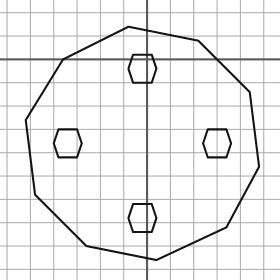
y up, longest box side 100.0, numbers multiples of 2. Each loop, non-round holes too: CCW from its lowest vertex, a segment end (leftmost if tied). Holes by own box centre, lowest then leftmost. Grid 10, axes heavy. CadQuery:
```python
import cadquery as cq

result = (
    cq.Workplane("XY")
    .moveTo(4.0, -86.0)
    .lineTo(34.0, -72.0)
    .lineTo(48.0, -46.0)
    .lineTo(44.0, -14.0)
    .lineTo(22.0, 8.0)
    .lineTo(-8.0, 14.0)
    .lineTo(-36.0, 0.0)
    .lineTo(-52.0, -26.0)
    .lineTo(-48.0, -58.0)
    .lineTo(-26.0, -80.0)
    .close()
    .moveTo(-6.0, -74.0)
    .lineTo(2.0, -74.0)
    .lineTo(4.0, -68.0)
    .lineTo(2.0, -62.0)
    .lineTo(-6.0, -62.0)
    .lineTo(-8.0, -68.0)
    .close()
    .moveTo(-38.0, -42.0)
    .lineTo(-30.0, -42.0)
    .lineTo(-28.0, -36.0)
    .lineTo(-30.0, -30.0)
    .lineTo(-38.0, -30.0)
    .lineTo(-40.0, -36.0)
    .close()
    .moveTo(26.0, -42.0)
    .lineTo(34.0, -42.0)
    .lineTo(36.0, -36.0)
    .lineTo(34.0, -30.0)
    .lineTo(26.0, -30.0)
    .lineTo(24.0, -36.0)
    .close()
    .moveTo(-6.0, -10.0)
    .lineTo(2.0, -10.0)
    .lineTo(4.0, -4.0)
    .lineTo(2.0, 2.0)
    .lineTo(-6.0, 2.0)
    .lineTo(-8.0, -4.0)
    .close()
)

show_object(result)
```